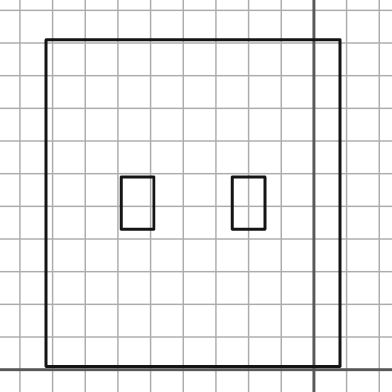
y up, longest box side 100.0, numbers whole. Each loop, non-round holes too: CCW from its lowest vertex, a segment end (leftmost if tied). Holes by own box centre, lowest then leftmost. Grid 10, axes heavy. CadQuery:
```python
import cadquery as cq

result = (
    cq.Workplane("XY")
    .moveTo(-82.0, 1.0)
    .lineTo(8.0, 1.0)
    .lineTo(8.0, 101.0)
    .lineTo(-82.0, 101.0)
    .close()
    .moveTo(-59.0, 43.0)
    .lineTo(-49.0, 43.0)
    .lineTo(-49.0, 59.0)
    .lineTo(-59.0, 59.0)
    .close()
    .moveTo(-25.0, 43.0)
    .lineTo(-15.0, 43.0)
    .lineTo(-15.0, 59.0)
    .lineTo(-25.0, 59.0)
    .close()
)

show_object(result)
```